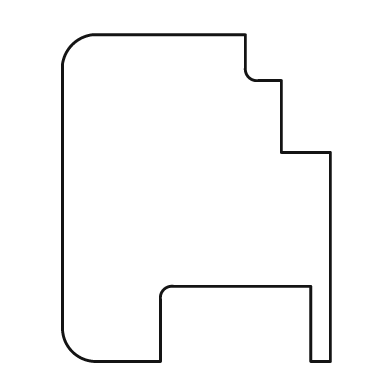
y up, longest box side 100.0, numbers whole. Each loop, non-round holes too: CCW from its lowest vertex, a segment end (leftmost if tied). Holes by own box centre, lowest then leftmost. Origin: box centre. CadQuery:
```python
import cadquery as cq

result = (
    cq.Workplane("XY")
    .moveTo(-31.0, -50.0)
    .lineTo(-11.0, -50.0)
    .lineTo(-11.0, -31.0)
    .threePointArc((-10.0, -28.0), (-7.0, -27.0))
    .lineTo(35.0, -27.0)
    .lineTo(35.0, -50.0)
    .lineTo(41.0, -50.0)
    .lineTo(41.0, 14.0)
    .lineTo(26.0, 14.0)
    .lineTo(26.0, 36.0)
    .lineTo(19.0, 36.0)
    .threePointArc((16.0, 37.0), (15.0, 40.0))
    .lineTo(15.0, 50.0)
    .lineTo(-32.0, 50.0)
    .threePointArc((-38.0, 47.0), (-41.0, 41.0))
    .lineTo(-41.0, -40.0)
    .threePointArc((-38.0, -47.0), (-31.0, -50.0))
    .close()
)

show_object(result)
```